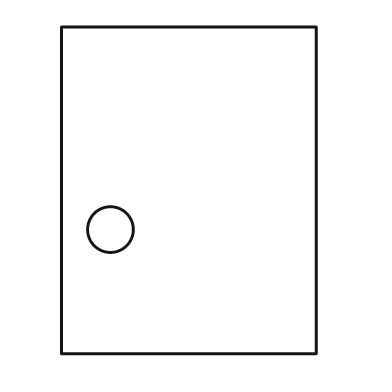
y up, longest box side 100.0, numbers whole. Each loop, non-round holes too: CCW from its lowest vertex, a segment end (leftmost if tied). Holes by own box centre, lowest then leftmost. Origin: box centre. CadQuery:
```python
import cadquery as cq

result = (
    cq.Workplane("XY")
    .moveTo(-39.0, -50.0)
    .lineTo(39.0, -50.0)
    .lineTo(39.0, 50.0)
    .lineTo(-39.0, 50.0)
    .close()
    .moveTo(-24.0, -12.0)
    .circle(7.0)
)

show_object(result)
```